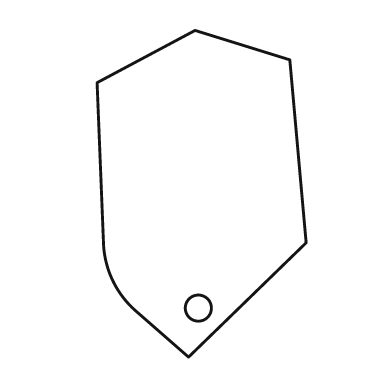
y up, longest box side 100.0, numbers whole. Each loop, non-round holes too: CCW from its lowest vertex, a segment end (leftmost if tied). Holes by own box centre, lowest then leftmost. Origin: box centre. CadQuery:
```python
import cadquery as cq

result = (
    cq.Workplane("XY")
    .moveTo(-4.0, -50.0)
    .lineTo(32.0, -15.0)
    .lineTo(27.0, 41.0)
    .lineTo(-2.0, 50.0)
    .lineTo(-32.0, 34.0)
    .lineTo(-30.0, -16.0)
    .threePointArc((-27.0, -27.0), (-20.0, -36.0))
    .close()
    .moveTo(-1.0, -35.0)
    .circle(4.0)
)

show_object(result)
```